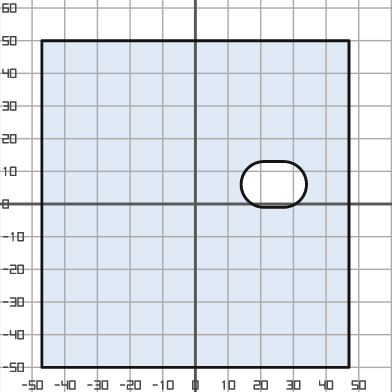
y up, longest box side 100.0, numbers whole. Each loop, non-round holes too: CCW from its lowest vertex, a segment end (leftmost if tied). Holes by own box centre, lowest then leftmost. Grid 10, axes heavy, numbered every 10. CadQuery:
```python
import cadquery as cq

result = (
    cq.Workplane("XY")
    .moveTo(-47.0, -50.0)
    .lineTo(47.0, -50.0)
    .lineTo(47.0, 50.0)
    .lineTo(-47.0, 50.0)
    .close()
    .moveTo(21.0, -1.0)
    .lineTo(27.0, -1.0)
    .threePointArc((34.0, 6.0), (27.0, 13.0))
    .lineTo(21.0, 13.0)
    .threePointArc((14.0, 6.0), (21.0, -1.0))
    .close()
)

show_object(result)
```